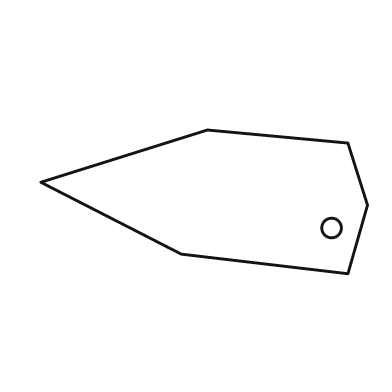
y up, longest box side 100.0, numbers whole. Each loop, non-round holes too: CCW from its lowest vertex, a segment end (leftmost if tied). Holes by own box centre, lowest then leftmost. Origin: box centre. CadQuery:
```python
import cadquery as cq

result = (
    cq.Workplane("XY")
    .moveTo(44.0, -22.0)
    .lineTo(50.0, -1.0)
    .lineTo(44.0, 18.0)
    .lineTo(1.0, 22.0)
    .lineTo(-50.0, 6.0)
    .lineTo(-7.0, -16.0)
    .close()
    .moveTo(39.0, -8.0)
    .circle(3.0)
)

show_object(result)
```